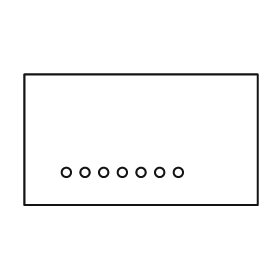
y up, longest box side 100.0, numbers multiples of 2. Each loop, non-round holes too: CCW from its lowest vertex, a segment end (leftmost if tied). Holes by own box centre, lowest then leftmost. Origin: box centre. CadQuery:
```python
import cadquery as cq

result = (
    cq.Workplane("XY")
    .moveTo(-50.0, -28.0)
    .lineTo(50.0, -28.0)
    .lineTo(50.0, 28.0)
    .lineTo(-50.0, 28.0)
    .close()
    .moveTo(-32.0, -14.0)
    .circle(2.0)
    .moveTo(-24.0, -14.0)
    .circle(2.0)
    .moveTo(-16.0, -14.0)
    .circle(2.0)
    .moveTo(-8.0, -14.0)
    .circle(2.0)
    .moveTo(0.0, -14.0)
    .circle(2.0)
    .moveTo(8.0, -14.0)
    .circle(2.0)
    .moveTo(16.0, -14.0)
    .circle(2.0)
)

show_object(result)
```